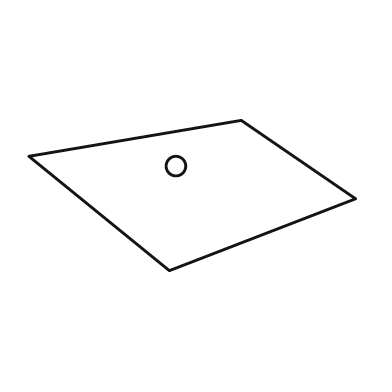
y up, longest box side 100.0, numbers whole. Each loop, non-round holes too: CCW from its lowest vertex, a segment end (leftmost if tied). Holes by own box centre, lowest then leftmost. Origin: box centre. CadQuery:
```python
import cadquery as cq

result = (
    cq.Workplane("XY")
    .moveTo(-7.0, -23.0)
    .lineTo(50.0, -1.0)
    .lineTo(15.0, 23.0)
    .lineTo(-50.0, 12.0)
    .close()
    .moveTo(-5.0, 9.0)
    .circle(3.0)
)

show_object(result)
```